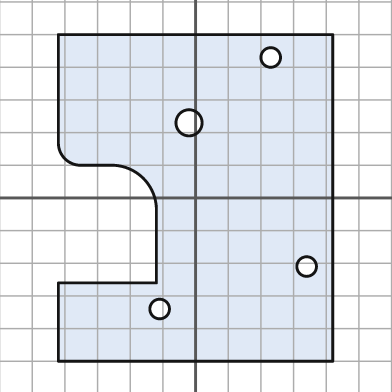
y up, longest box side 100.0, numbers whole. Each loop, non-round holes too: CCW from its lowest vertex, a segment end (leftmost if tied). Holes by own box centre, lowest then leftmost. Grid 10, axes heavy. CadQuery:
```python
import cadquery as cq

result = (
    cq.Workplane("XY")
    .moveTo(-42.0, -50.0)
    .lineTo(42.0, -50.0)
    .lineTo(42.0, 50.0)
    .lineTo(-42.0, 50.0)
    .lineTo(-42.0, 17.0)
    .threePointArc((-40.0, 12.0), (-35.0, 10.0))
    .lineTo(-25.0, 10.0)
    .threePointArc((-16.0, 6.0), (-12.0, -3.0))
    .lineTo(-12.0, -26.0)
    .lineTo(-42.0, -26.0)
    .close()
    .moveTo(-11.0, -34.0)
    .circle(3.0)
    .moveTo(34.0, -21.0)
    .circle(3.0)
    .moveTo(-2.0, 23.0)
    .circle(4.0)
    .moveTo(23.0, 43.0)
    .circle(3.0)
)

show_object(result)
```